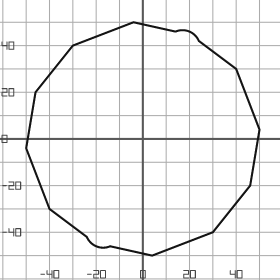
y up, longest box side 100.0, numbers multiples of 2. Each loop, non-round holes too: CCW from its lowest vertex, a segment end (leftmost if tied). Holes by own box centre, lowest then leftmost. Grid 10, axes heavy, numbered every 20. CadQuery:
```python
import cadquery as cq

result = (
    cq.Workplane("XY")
    .moveTo(4.0, -50.0)
    .lineTo(30.0, -40.0)
    .lineTo(46.0, -20.0)
    .lineTo(50.0, 4.0)
    .lineTo(40.0, 30.0)
    .lineTo(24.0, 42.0)
    .threePointArc((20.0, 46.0), (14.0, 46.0))
    .lineTo(-4.0, 50.0)
    .lineTo(-30.0, 40.0)
    .lineTo(-46.0, 20.0)
    .lineTo(-50.0, -4.0)
    .lineTo(-40.0, -30.0)
    .lineTo(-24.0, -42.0)
    .threePointArc((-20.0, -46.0), (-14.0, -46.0))
    .close()
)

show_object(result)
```